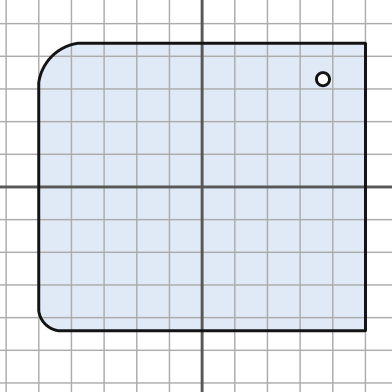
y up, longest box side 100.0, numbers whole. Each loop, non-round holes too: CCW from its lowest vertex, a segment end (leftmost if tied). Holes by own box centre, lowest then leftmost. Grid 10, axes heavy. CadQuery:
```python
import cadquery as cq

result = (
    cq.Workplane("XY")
    .moveTo(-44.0, -44.0)
    .lineTo(50.0, -44.0)
    .lineTo(50.0, 44.0)
    .lineTo(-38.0, 44.0)
    .threePointArc((-46.0, 40.0), (-50.0, 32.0))
    .lineTo(-50.0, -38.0)
    .threePointArc((-48.0, -42.0), (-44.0, -44.0))
    .close()
    .moveTo(37.0, 33.0)
    .circle(2.0)
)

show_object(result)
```